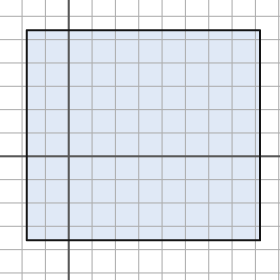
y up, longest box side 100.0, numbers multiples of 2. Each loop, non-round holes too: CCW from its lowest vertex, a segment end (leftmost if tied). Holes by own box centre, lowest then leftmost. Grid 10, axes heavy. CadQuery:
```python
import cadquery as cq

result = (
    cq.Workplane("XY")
    .moveTo(-18.0, -36.0)
    .lineTo(82.0, -36.0)
    .lineTo(82.0, 54.0)
    .lineTo(-18.0, 54.0)
    .close()
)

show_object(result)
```